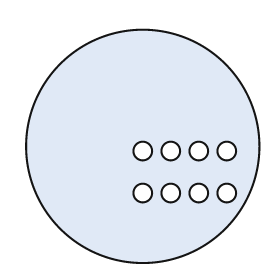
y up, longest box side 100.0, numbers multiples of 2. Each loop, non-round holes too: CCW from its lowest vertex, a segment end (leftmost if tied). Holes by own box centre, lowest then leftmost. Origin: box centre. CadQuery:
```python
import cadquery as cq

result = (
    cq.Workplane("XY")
    .moveTo(0.0, 0.0)
    .circle(50.0)
    .moveTo(0.0, -20.0)
    .circle(4.0)
    .moveTo(12.0, -20.0)
    .circle(4.0)
    .moveTo(24.0, -20.0)
    .circle(4.0)
    .moveTo(36.0, -20.0)
    .circle(4.0)
    .moveTo(0.0, -2.0)
    .circle(4.0)
    .moveTo(12.0, -2.0)
    .circle(4.0)
    .moveTo(24.0, -2.0)
    .circle(4.0)
    .moveTo(36.0, -2.0)
    .circle(4.0)
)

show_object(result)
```